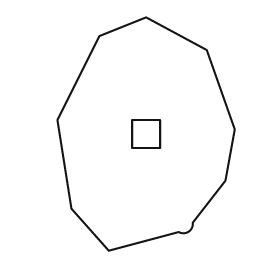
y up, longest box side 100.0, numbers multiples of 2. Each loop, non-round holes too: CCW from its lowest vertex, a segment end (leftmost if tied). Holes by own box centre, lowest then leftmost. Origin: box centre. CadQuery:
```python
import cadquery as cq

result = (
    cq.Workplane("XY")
    .moveTo(-16.0, -50.0)
    .lineTo(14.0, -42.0)
    .threePointArc((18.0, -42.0), (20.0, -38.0))
    .lineTo(34.0, -20.0)
    .lineTo(38.0, 2.0)
    .lineTo(26.0, 36.0)
    .lineTo(0.0, 50.0)
    .lineTo(-20.0, 42.0)
    .lineTo(-38.0, 6.0)
    .lineTo(-32.0, -32.0)
    .close()
    .moveTo(-6.0, -6.0)
    .lineTo(6.0, -6.0)
    .lineTo(6.0, 6.0)
    .lineTo(-6.0, 6.0)
    .close()
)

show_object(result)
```